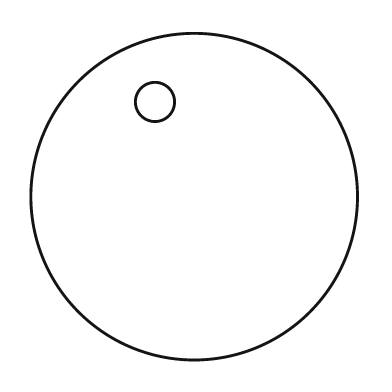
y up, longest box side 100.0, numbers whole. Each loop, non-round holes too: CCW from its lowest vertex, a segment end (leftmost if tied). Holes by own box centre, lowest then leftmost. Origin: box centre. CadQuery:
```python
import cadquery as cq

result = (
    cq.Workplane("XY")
    .moveTo(0.0, 0.0)
    .circle(50.0)
    .moveTo(-12.0, 29.0)
    .circle(6.0)
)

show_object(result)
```